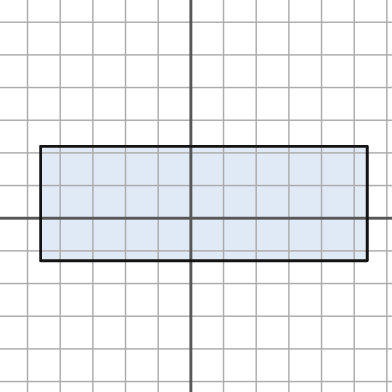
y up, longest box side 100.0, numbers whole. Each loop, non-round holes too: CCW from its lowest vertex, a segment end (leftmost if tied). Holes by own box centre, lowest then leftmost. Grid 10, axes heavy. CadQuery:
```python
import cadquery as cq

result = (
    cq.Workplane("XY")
    .moveTo(-46.0, -13.0)
    .lineTo(54.0, -13.0)
    .lineTo(54.0, 22.0)
    .lineTo(-46.0, 22.0)
    .close()
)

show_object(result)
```